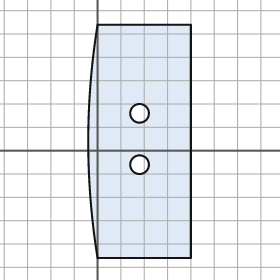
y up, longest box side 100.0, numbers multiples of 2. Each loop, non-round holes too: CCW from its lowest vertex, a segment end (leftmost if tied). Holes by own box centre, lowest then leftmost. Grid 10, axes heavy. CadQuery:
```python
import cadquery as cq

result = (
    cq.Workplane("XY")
    .moveTo(0.0, -46.0)
    .lineTo(40.0, -46.0)
    .lineTo(40.0, 54.0)
    .lineTo(0.0, 54.0)
    .threePointArc((-4.0, 4.0), (0.0, -46.0))
    .close()
    .moveTo(18.0, -6.0)
    .circle(4.0)
    .moveTo(18.0, 16.0)
    .circle(4.0)
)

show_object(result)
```